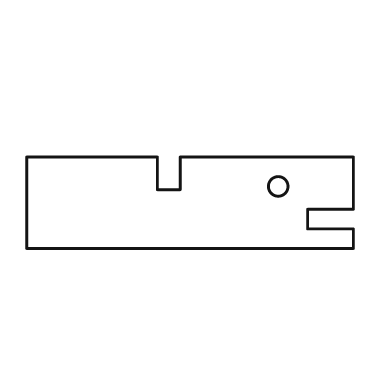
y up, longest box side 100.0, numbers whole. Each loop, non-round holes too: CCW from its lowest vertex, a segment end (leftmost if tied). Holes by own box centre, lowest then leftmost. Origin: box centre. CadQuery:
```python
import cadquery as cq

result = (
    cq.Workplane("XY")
    .moveTo(-50.0, -14.0)
    .lineTo(50.0, -14.0)
    .lineTo(50.0, -8.0)
    .lineTo(36.0, -8.0)
    .lineTo(36.0, -2.0)
    .lineTo(50.0, -2.0)
    .lineTo(50.0, 14.0)
    .lineTo(-3.0, 14.0)
    .lineTo(-3.0, 4.0)
    .lineTo(-10.0, 4.0)
    .lineTo(-10.0, 14.0)
    .lineTo(-50.0, 14.0)
    .close()
    .moveTo(27.0, 5.0)
    .circle(3.0)
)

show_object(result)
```